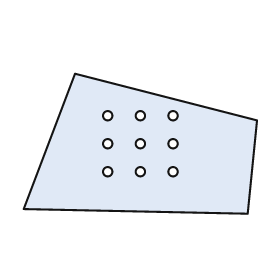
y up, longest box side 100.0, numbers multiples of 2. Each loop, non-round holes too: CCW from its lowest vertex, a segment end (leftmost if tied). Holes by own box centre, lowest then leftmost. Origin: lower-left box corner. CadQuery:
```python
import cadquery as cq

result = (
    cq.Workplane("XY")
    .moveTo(96.0, 0.0)
    .lineTo(100.0, 40.0)
    .lineTo(22.0, 60.0)
    .lineTo(0.0, 2.0)
    .close()
    .moveTo(36.0, 18.0)
    .circle(2.0)
    .moveTo(50.0, 18.0)
    .circle(2.0)
    .moveTo(64.0, 18.0)
    .circle(2.0)
    .moveTo(36.0, 30.0)
    .circle(2.0)
    .moveTo(50.0, 30.0)
    .circle(2.0)
    .moveTo(64.0, 30.0)
    .circle(2.0)
    .moveTo(36.0, 42.0)
    .circle(2.0)
    .moveTo(50.0, 42.0)
    .circle(2.0)
    .moveTo(64.0, 42.0)
    .circle(2.0)
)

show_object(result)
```